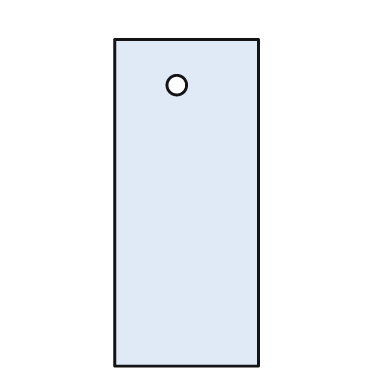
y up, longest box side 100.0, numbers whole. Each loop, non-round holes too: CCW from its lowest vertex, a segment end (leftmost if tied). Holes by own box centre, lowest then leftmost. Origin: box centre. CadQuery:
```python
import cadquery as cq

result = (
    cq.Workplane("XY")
    .moveTo(-22.0, -50.0)
    .lineTo(22.0, -50.0)
    .lineTo(22.0, 50.0)
    .lineTo(-22.0, 50.0)
    .close()
    .moveTo(-3.0, 36.0)
    .circle(3.0)
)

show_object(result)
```